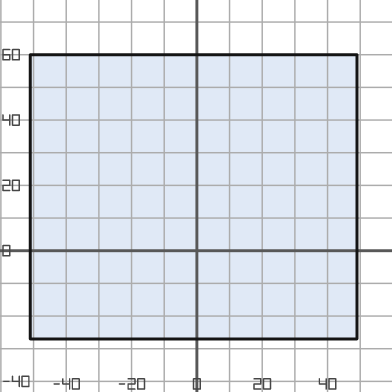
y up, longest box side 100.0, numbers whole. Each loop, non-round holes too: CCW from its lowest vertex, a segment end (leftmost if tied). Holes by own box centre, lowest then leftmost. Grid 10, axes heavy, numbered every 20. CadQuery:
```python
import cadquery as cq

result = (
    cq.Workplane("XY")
    .moveTo(-51.0, -27.0)
    .lineTo(49.0, -27.0)
    .lineTo(49.0, 60.0)
    .lineTo(-51.0, 60.0)
    .close()
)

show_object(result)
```